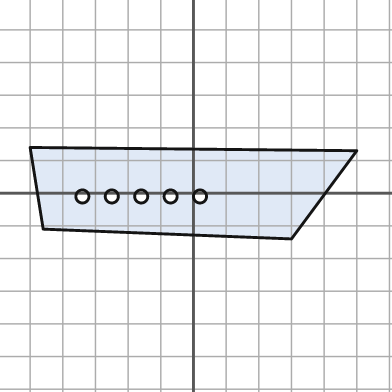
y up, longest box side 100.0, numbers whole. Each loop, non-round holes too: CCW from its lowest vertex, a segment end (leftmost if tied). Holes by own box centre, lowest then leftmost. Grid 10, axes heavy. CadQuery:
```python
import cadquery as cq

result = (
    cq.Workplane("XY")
    .moveTo(30.0, -14.0)
    .lineTo(50.0, 13.0)
    .lineTo(-50.0, 14.0)
    .lineTo(-46.0, -11.0)
    .close()
    .moveTo(-34.0, -1.0)
    .circle(2.0)
    .moveTo(-25.0, -1.0)
    .circle(2.0)
    .moveTo(-16.0, -1.0)
    .circle(2.0)
    .moveTo(-7.0, -1.0)
    .circle(2.0)
    .moveTo(2.0, -1.0)
    .circle(2.0)
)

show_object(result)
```